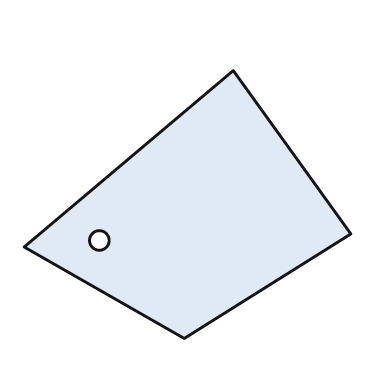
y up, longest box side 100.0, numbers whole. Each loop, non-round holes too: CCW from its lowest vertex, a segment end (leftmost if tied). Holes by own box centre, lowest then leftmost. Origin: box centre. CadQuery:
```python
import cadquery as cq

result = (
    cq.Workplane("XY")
    .moveTo(-1.0, -41.0)
    .lineTo(50.0, -9.0)
    .lineTo(14.0, 41.0)
    .lineTo(-50.0, -13.0)
    .close()
    .moveTo(-27.0, -11.0)
    .circle(3.0)
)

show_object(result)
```